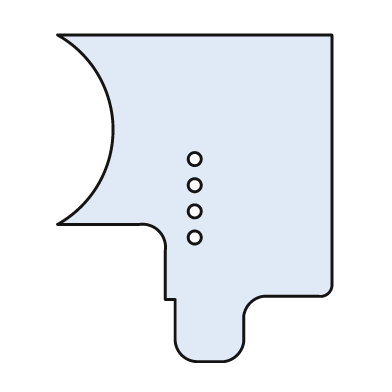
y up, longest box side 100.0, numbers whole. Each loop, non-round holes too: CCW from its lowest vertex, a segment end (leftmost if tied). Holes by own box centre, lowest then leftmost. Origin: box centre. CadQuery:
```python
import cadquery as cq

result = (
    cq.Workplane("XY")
    .moveTo(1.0, -50.0)
    .lineTo(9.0, -50.0)
    .threePointArc((13.0, -48.0), (15.0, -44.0))
    .lineTo(15.0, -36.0)
    .threePointArc((17.0, -32.0), (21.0, -30.0))
    .lineTo(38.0, -30.0)
    .threePointArc((41.0, -29.0), (42.0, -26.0))
    .lineTo(42.0, 50.0)
    .lineTo(-42.0, 50.0)
    .threePointArc((-25.0, 21.0), (-42.0, -8.0))
    .lineTo(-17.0, -8.0)
    .threePointArc((-11.0, -10.0), (-9.0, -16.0))
    .lineTo(-9.0, -31.0)
    .lineTo(-6.0, -31.0)
    .lineTo(-6.0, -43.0)
    .threePointArc((-4.0, -48.0), (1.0, -50.0))
    .close()
    .moveTo(0.0, -12.0)
    .circle(2.0)
    .moveTo(0.0, -4.0)
    .circle(2.0)
    .moveTo(0.0, 4.0)
    .circle(2.0)
    .moveTo(0.0, 12.0)
    .circle(2.0)
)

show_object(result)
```